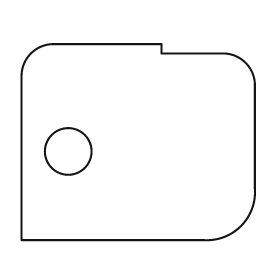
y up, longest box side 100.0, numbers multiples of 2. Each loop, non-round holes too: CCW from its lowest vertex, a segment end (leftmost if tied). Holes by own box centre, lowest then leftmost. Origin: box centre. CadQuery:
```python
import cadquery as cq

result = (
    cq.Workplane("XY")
    .moveTo(-50.0, -42.0)
    .lineTo(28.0, -42.0)
    .threePointArc((44.0, -36.0), (50.0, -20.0))
    .lineTo(50.0, 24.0)
    .threePointArc((46.0, 34.0), (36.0, 38.0))
    .lineTo(10.0, 38.0)
    .lineTo(10.0, 42.0)
    .lineTo(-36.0, 42.0)
    .threePointArc((-46.0, 38.0), (-50.0, 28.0))
    .close()
    .moveTo(-30.0, -4.0)
    .circle(10.0)
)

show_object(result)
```